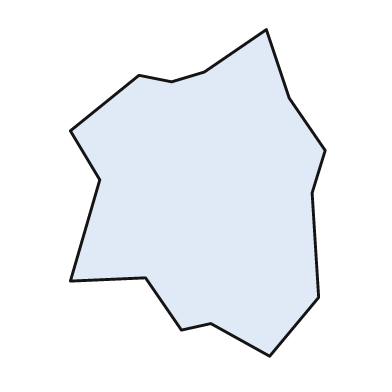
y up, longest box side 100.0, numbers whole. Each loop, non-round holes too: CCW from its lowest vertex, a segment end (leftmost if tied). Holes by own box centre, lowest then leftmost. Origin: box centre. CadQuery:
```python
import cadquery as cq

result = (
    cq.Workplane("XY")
    .moveTo(22.0, -50.0)
    .lineTo(37.0, -32.0)
    .lineTo(35.0, 0.0)
    .lineTo(39.0, 13.0)
    .lineTo(28.0, 29.0)
    .lineTo(21.0, 50.0)
    .lineTo(2.0, 37.0)
    .lineTo(-8.0, 34.0)
    .lineTo(-18.0, 36.0)
    .lineTo(-39.0, 19.0)
    .lineTo(-30.0, 4.0)
    .lineTo(-39.0, -27.0)
    .lineTo(-16.0, -26.0)
    .lineTo(-5.0, -42.0)
    .lineTo(4.0, -40.0)
    .close()
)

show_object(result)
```